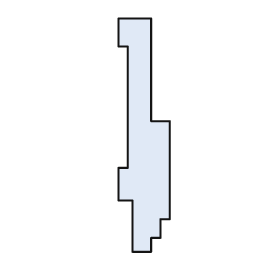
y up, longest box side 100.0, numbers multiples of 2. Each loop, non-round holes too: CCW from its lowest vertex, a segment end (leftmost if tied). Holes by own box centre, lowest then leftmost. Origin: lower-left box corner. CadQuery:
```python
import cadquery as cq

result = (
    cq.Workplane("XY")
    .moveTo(6.0, 0.0)
    .lineTo(14.0, 0.0)
    .lineTo(14.0, 6.0)
    .lineTo(18.0, 6.0)
    .lineTo(18.0, 14.0)
    .lineTo(22.0, 14.0)
    .lineTo(22.0, 56.0)
    .lineTo(14.0, 56.0)
    .lineTo(14.0, 100.0)
    .lineTo(0.0, 100.0)
    .lineTo(0.0, 88.0)
    .lineTo(4.0, 88.0)
    .lineTo(4.0, 36.0)
    .lineTo(0.0, 36.0)
    .lineTo(0.0, 22.0)
    .lineTo(6.0, 22.0)
    .close()
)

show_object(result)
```